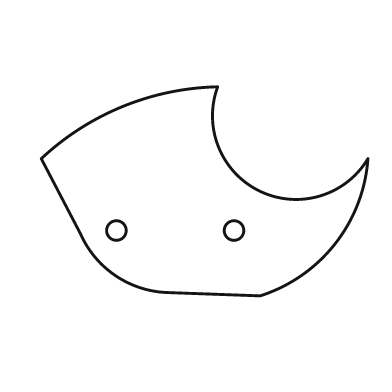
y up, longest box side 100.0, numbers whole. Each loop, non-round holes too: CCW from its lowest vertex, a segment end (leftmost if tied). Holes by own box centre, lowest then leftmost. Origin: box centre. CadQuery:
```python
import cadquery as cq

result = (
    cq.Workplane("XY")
    .moveTo(17.0, -32.0)
    .threePointArc((40.0, -16.0), (50.0, 10.0))
    .threePointArc((17.0, 0.0), (4.0, 32.0))
    .threePointArc((-25.0, 26.0), (-50.0, 10.0))
    .lineTo(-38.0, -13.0)
    .threePointArc((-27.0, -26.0), (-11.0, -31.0))
    .close()
    .moveTo(-27.0, -12.0)
    .circle(3.0)
    .moveTo(9.0, -12.0)
    .circle(3.0)
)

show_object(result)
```